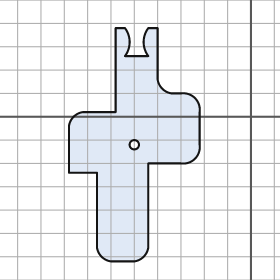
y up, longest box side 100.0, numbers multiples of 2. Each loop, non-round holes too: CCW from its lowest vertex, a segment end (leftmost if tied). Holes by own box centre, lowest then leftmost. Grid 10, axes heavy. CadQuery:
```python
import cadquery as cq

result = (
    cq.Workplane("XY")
    .moveTo(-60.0, -62.0)
    .lineTo(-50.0, -62.0)
    .threePointArc((-46.0, -60.0), (-44.0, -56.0))
    .lineTo(-44.0, -20.0)
    .lineTo(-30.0, -20.0)
    .threePointArc((-24.0, -18.0), (-22.0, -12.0))
    .lineTo(-22.0, 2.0)
    .threePointArc((-24.0, 8.0), (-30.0, 10.0))
    .lineTo(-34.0, 10.0)
    .threePointArc((-38.0, 12.0), (-40.0, 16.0))
    .lineTo(-40.0, 38.0)
    .lineTo(-44.0, 38.0)
    .threePointArc((-46.0, 32.0), (-44.0, 26.0))
    .lineTo(-54.0, 26.0)
    .threePointArc((-52.0, 32.0), (-54.0, 38.0))
    .lineTo(-58.0, 38.0)
    .lineTo(-58.0, 2.0)
    .lineTo(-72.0, 2.0)
    .threePointArc((-76.0, 0.0), (-78.0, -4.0))
    .lineTo(-78.0, -24.0)
    .lineTo(-66.0, -24.0)
    .lineTo(-66.0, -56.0)
    .threePointArc((-64.0, -60.0), (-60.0, -62.0))
    .close()
    .moveTo(-50.0, -12.0)
    .circle(2.0)
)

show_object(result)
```